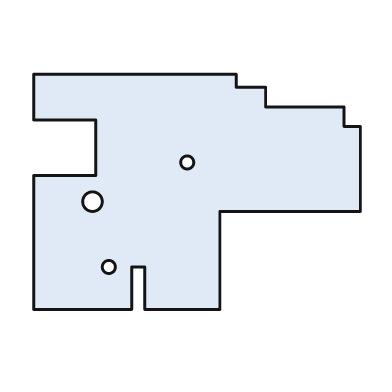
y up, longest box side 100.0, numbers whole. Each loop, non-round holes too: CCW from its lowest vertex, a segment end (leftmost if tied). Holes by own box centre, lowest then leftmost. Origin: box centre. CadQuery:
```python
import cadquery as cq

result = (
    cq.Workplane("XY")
    .moveTo(-50.0, -36.0)
    .lineTo(-20.0, -36.0)
    .lineTo(-20.0, -23.0)
    .lineTo(-16.0, -23.0)
    .lineTo(-16.0, -36.0)
    .lineTo(7.0, -36.0)
    .lineTo(7.0, -6.0)
    .lineTo(50.0, -6.0)
    .lineTo(50.0, 20.0)
    .lineTo(45.0, 20.0)
    .lineTo(45.0, 26.0)
    .lineTo(21.0, 26.0)
    .lineTo(21.0, 32.0)
    .lineTo(12.0, 32.0)
    .lineTo(12.0, 36.0)
    .lineTo(-50.0, 36.0)
    .lineTo(-50.0, 22.0)
    .lineTo(-31.0, 22.0)
    .lineTo(-31.0, 5.0)
    .lineTo(-50.0, 5.0)
    .close()
    .moveTo(-27.0, -23.0)
    .circle(2.0)
    .moveTo(-32.0, -3.0)
    .circle(3.0)
    .moveTo(-3.0, 9.0)
    .circle(2.0)
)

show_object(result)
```